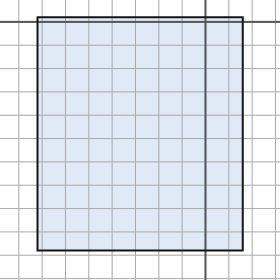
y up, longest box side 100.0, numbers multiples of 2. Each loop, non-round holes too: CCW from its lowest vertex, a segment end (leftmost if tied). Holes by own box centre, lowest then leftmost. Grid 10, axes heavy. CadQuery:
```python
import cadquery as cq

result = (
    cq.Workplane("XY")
    .moveTo(-72.0, -98.0)
    .lineTo(16.0, -98.0)
    .lineTo(16.0, 2.0)
    .lineTo(-72.0, 2.0)
    .close()
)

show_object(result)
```